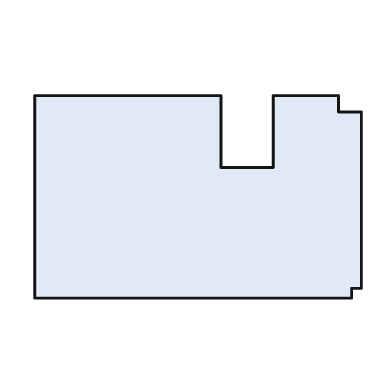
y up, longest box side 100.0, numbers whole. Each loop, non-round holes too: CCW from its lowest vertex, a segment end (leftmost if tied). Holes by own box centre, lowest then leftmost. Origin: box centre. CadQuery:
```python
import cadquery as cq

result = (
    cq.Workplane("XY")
    .moveTo(-50.0, -31.0)
    .lineTo(47.0, -31.0)
    .lineTo(47.0, -28.0)
    .lineTo(50.0, -28.0)
    .lineTo(50.0, 26.0)
    .lineTo(43.0, 26.0)
    .lineTo(43.0, 31.0)
    .lineTo(23.0, 31.0)
    .lineTo(23.0, 9.0)
    .lineTo(7.0, 9.0)
    .lineTo(7.0, 31.0)
    .lineTo(-50.0, 31.0)
    .close()
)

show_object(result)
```